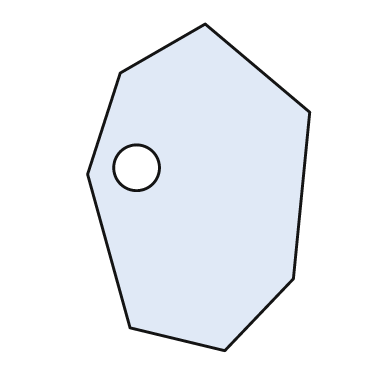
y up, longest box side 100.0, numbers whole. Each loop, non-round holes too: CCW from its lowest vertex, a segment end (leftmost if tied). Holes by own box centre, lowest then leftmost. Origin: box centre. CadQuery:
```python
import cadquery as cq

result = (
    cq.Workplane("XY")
    .moveTo(8.0, -50.0)
    .lineTo(29.0, -28.0)
    .lineTo(34.0, 23.0)
    .lineTo(2.0, 50.0)
    .lineTo(-24.0, 35.0)
    .lineTo(-34.0, 4.0)
    .lineTo(-21.0, -43.0)
    .close()
    .moveTo(-19.0, 6.0)
    .circle(7.0)
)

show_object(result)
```